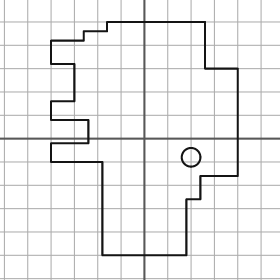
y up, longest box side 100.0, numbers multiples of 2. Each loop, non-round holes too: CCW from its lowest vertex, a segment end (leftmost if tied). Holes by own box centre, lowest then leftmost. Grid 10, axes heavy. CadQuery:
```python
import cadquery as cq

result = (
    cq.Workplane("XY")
    .moveTo(-18.0, -50.0)
    .lineTo(18.0, -50.0)
    .lineTo(18.0, -26.0)
    .lineTo(24.0, -26.0)
    .lineTo(24.0, -16.0)
    .lineTo(40.0, -16.0)
    .lineTo(40.0, 30.0)
    .lineTo(26.0, 30.0)
    .lineTo(26.0, 50.0)
    .lineTo(-16.0, 50.0)
    .lineTo(-16.0, 46.0)
    .lineTo(-26.0, 46.0)
    .lineTo(-26.0, 42.0)
    .lineTo(-40.0, 42.0)
    .lineTo(-40.0, 32.0)
    .lineTo(-30.0, 32.0)
    .lineTo(-30.0, 16.0)
    .lineTo(-40.0, 16.0)
    .lineTo(-40.0, 8.0)
    .lineTo(-24.0, 8.0)
    .lineTo(-24.0, -2.0)
    .lineTo(-40.0, -2.0)
    .lineTo(-40.0, -10.0)
    .lineTo(-18.0, -10.0)
    .close()
    .moveTo(20.0, -8.0)
    .circle(4.0)
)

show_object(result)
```